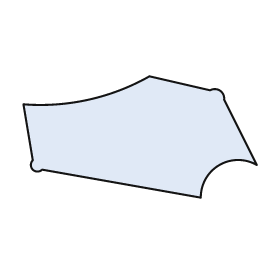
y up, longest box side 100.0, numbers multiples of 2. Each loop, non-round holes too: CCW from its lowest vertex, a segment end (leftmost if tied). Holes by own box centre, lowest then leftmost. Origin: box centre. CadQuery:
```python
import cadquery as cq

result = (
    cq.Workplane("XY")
    .moveTo(26.0, -26.0)
    .threePointArc((34.0, -12.0), (50.0, -12.0))
    .lineTo(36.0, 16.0)
    .threePointArc((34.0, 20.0), (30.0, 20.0))
    .lineTo(4.0, 26.0)
    .threePointArc((-22.0, 16.0), (-50.0, 14.0))
    .lineTo(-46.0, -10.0)
    .threePointArc((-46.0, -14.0), (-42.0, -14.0))
    .close()
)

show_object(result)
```